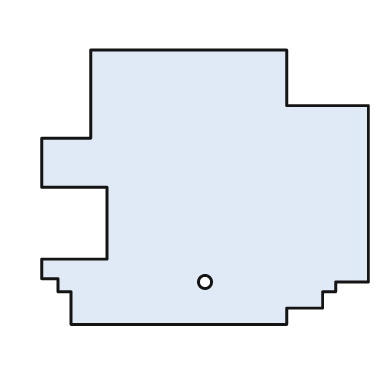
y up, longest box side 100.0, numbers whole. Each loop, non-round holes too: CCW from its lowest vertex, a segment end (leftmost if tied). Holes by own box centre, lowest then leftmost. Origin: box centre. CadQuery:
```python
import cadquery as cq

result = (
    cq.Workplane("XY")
    .moveTo(-41.0, -42.0)
    .lineTo(25.0, -42.0)
    .lineTo(25.0, -37.0)
    .lineTo(36.0, -37.0)
    .lineTo(36.0, -32.0)
    .lineTo(40.0, -32.0)
    .lineTo(40.0, -29.0)
    .lineTo(50.0, -29.0)
    .lineTo(50.0, 25.0)
    .lineTo(25.0, 25.0)
    .lineTo(25.0, 42.0)
    .lineTo(-35.0, 42.0)
    .lineTo(-35.0, 15.0)
    .lineTo(-50.0, 15.0)
    .lineTo(-50.0, 0.0)
    .lineTo(-30.0, 0.0)
    .lineTo(-30.0, -22.0)
    .lineTo(-50.0, -22.0)
    .lineTo(-50.0, -28.0)
    .lineTo(-45.0, -28.0)
    .lineTo(-45.0, -32.0)
    .lineTo(-41.0, -32.0)
    .close()
    .moveTo(0.0, -29.0)
    .circle(2.0)
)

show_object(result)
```